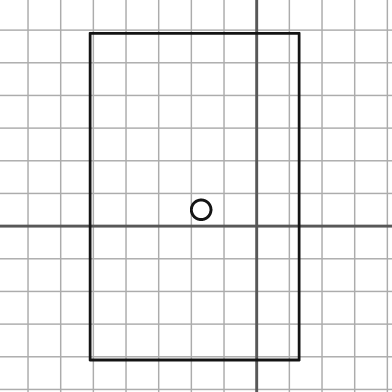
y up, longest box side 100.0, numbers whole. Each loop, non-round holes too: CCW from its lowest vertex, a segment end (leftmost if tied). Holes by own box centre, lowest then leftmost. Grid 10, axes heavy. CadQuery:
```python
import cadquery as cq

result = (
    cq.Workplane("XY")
    .moveTo(-51.0, -41.0)
    .lineTo(13.0, -41.0)
    .lineTo(13.0, 59.0)
    .lineTo(-51.0, 59.0)
    .close()
    .moveTo(-17.0, 5.0)
    .circle(3.0)
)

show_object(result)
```